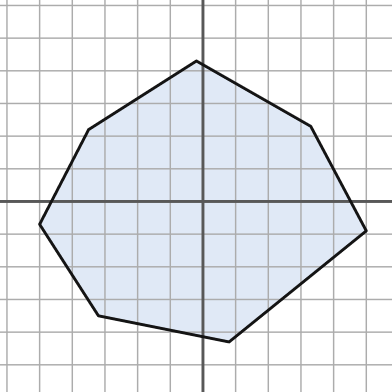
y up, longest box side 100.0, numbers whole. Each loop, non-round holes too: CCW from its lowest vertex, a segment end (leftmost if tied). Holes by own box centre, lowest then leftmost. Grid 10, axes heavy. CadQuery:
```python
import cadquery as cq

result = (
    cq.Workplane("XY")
    .moveTo(8.0, -43.0)
    .lineTo(50.0, -9.0)
    .lineTo(33.0, 23.0)
    .lineTo(-2.0, 43.0)
    .lineTo(-35.0, 22.0)
    .lineTo(-50.0, -7.0)
    .lineTo(-32.0, -35.0)
    .close()
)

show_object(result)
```